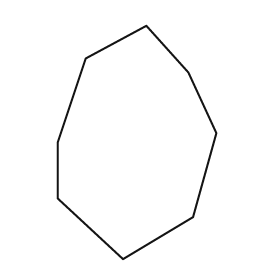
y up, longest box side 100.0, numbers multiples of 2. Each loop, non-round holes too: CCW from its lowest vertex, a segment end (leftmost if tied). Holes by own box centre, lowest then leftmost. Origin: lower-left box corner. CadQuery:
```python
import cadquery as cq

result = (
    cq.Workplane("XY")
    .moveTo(28.0, 0.0)
    .lineTo(58.0, 18.0)
    .lineTo(68.0, 54.0)
    .lineTo(56.0, 80.0)
    .lineTo(38.0, 100.0)
    .lineTo(12.0, 86.0)
    .lineTo(0.0, 50.0)
    .lineTo(0.0, 26.0)
    .close()
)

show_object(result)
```